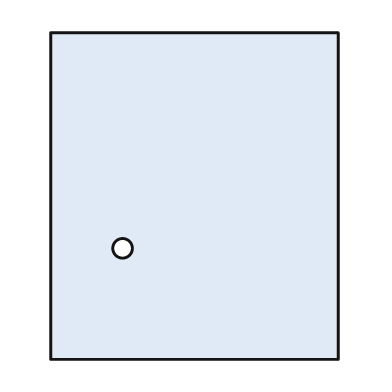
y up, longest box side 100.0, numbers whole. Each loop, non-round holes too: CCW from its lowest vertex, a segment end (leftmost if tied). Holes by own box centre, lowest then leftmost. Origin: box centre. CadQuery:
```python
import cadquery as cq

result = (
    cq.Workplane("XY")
    .moveTo(-44.0, -50.0)
    .lineTo(44.0, -50.0)
    .lineTo(44.0, 50.0)
    .lineTo(-44.0, 50.0)
    .close()
    .moveTo(-22.0, -16.0)
    .circle(3.0)
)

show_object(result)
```